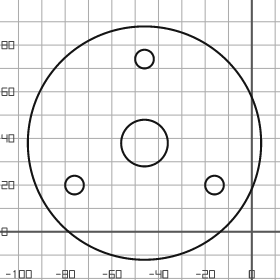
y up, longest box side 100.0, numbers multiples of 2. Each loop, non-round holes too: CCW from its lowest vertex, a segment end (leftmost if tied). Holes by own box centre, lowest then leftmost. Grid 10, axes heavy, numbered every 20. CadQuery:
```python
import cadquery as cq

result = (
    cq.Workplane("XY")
    .moveTo(-46.0, 38.0)
    .circle(50.0)
    .moveTo(-76.0, 20.0)
    .circle(4.0)
    .moveTo(-16.0, 20.0)
    .circle(4.0)
    .moveTo(-46.0, 38.0)
    .circle(10.0)
    .moveTo(-46.0, 74.0)
    .circle(4.0)
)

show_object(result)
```